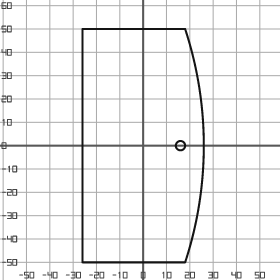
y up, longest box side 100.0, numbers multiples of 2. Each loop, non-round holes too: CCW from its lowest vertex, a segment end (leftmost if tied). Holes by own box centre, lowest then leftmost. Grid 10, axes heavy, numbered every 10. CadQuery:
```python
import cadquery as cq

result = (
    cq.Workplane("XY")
    .moveTo(-26.0, -50.0)
    .lineTo(18.0, -50.0)
    .threePointArc((26.0, 0.0), (18.0, 50.0))
    .lineTo(-26.0, 50.0)
    .close()
    .moveTo(16.0, 0.0)
    .circle(2.0)
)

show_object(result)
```